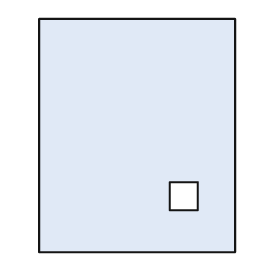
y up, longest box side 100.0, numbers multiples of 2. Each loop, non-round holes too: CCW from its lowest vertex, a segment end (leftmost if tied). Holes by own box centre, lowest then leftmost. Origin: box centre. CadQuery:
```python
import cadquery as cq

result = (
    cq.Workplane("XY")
    .moveTo(-42.0, -50.0)
    .lineTo(42.0, -50.0)
    .lineTo(42.0, 50.0)
    .lineTo(-42.0, 50.0)
    .close()
    .moveTo(14.0, -32.0)
    .lineTo(26.0, -32.0)
    .lineTo(26.0, -20.0)
    .lineTo(14.0, -20.0)
    .close()
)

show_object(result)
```